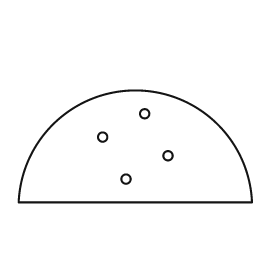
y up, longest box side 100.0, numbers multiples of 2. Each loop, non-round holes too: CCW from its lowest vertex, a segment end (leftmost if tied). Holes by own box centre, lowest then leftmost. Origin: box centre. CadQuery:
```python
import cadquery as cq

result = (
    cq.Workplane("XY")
    .moveTo(-50.0, -24.0)
    .lineTo(50.0, -24.0)
    .threePointArc((0.0, 24.0), (-50.0, -24.0))
    .close()
    .moveTo(-4.0, -14.0)
    .circle(2.0)
    .moveTo(14.0, -4.0)
    .circle(2.0)
    .moveTo(-14.0, 4.0)
    .circle(2.0)
    .moveTo(4.0, 14.0)
    .circle(2.0)
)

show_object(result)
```